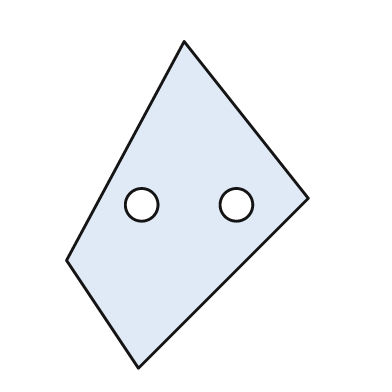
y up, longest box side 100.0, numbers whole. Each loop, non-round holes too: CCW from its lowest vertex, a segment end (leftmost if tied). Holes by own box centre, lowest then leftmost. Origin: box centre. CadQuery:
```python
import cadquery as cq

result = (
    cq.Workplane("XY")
    .moveTo(-15.0, -50.0)
    .lineTo(37.0, 2.0)
    .lineTo(-1.0, 50.0)
    .lineTo(-37.0, -17.0)
    .close()
    .moveTo(-14.0, 0.0)
    .circle(5.0)
    .moveTo(15.0, 0.0)
    .circle(5.0)
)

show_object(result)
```